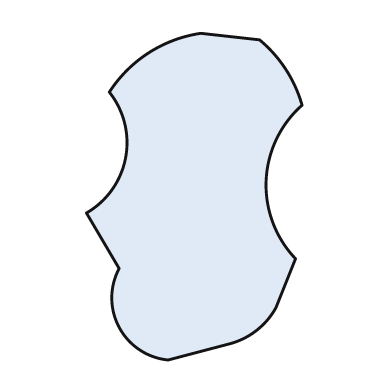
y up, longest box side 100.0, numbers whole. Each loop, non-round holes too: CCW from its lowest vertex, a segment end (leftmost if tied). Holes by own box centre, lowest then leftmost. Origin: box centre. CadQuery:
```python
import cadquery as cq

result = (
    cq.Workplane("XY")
    .moveTo(-8.0, -50.0)
    .lineTo(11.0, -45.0)
    .threePointArc((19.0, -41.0), (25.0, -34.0))
    .lineTo(31.0, -19.0)
    .threePointArc((22.0, 5.0), (33.0, 28.0))
    .threePointArc((28.0, 39.0), (20.0, 48.0))
    .lineTo(2.0, 50.0)
    .threePointArc((-14.0, 44.0), (-26.0, 32.0))
    .threePointArc((-21.0, 12.0), (-33.0, -5.0))
    .lineTo(-23.0, -22.0)
    .threePointArc((-23.0, -40.0), (-8.0, -50.0))
    .close()
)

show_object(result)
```